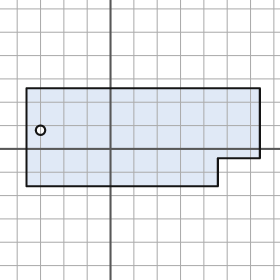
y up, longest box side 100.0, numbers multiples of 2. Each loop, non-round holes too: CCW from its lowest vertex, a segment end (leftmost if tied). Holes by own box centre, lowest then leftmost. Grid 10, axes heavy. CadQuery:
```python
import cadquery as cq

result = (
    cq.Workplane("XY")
    .moveTo(-36.0, -16.0)
    .lineTo(46.0, -16.0)
    .lineTo(46.0, -4.0)
    .lineTo(64.0, -4.0)
    .lineTo(64.0, 26.0)
    .lineTo(-36.0, 26.0)
    .close()
    .moveTo(-30.0, 8.0)
    .circle(2.0)
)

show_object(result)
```